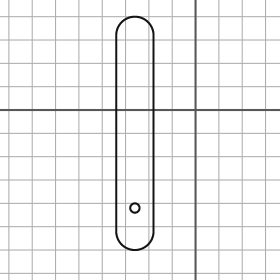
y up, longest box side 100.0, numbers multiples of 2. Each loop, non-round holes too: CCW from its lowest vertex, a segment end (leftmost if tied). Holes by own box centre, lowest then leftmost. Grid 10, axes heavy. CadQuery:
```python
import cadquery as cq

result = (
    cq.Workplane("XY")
    .moveTo(-34.0, -52.0)
    .threePointArc((-26.0, -60.0), (-18.0, -52.0))
    .lineTo(-18.0, 32.0)
    .threePointArc((-26.0, 40.0), (-34.0, 32.0))
    .close()
    .moveTo(-26.0, -42.0)
    .circle(2.0)
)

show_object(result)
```